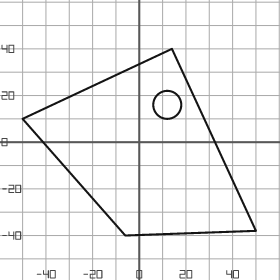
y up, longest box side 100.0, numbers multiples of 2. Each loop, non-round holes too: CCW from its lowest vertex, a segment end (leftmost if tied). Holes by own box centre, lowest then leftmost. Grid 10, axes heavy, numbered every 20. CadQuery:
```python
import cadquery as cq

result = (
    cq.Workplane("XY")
    .moveTo(-6.0, -40.0)
    .lineTo(50.0, -38.0)
    .lineTo(14.0, 40.0)
    .lineTo(-50.0, 10.0)
    .close()
    .moveTo(12.0, 16.0)
    .circle(6.0)
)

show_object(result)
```